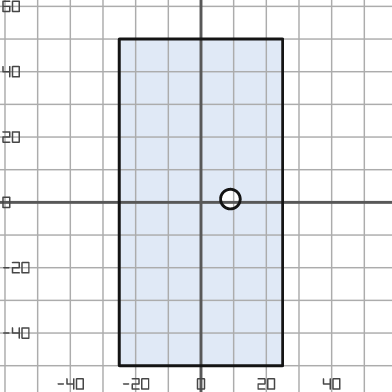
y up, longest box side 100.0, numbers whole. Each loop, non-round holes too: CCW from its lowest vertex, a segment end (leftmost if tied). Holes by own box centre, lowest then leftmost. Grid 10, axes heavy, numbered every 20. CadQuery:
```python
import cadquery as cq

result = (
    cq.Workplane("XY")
    .moveTo(-25.0, -50.0)
    .lineTo(25.0, -50.0)
    .lineTo(25.0, 50.0)
    .lineTo(-25.0, 50.0)
    .close()
    .moveTo(9.0, 1.0)
    .circle(3.0)
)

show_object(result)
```